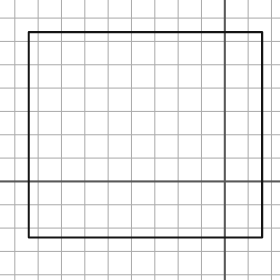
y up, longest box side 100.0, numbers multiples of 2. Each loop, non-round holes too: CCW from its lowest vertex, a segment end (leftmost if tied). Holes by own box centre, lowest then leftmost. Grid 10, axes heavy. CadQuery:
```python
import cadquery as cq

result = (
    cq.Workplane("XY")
    .moveTo(-84.0, -24.0)
    .lineTo(16.0, -24.0)
    .lineTo(16.0, 64.0)
    .lineTo(-84.0, 64.0)
    .close()
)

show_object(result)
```